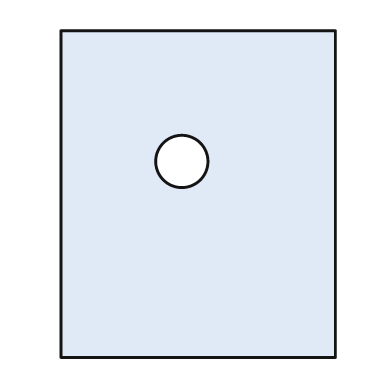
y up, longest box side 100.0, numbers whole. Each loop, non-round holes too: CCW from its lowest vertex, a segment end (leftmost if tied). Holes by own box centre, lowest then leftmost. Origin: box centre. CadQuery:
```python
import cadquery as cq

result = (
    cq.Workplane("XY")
    .moveTo(-42.0, -50.0)
    .lineTo(42.0, -50.0)
    .lineTo(42.0, 50.0)
    .lineTo(-42.0, 50.0)
    .close()
    .moveTo(-5.0, 10.0)
    .circle(8.0)
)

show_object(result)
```